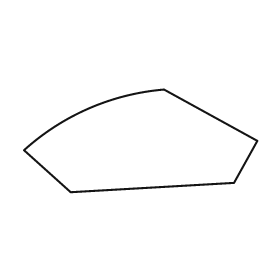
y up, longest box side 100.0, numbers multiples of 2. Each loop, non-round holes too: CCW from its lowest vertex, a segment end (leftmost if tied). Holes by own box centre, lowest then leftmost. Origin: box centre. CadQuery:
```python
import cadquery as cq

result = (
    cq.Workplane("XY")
    .moveTo(-30.0, -22.0)
    .lineTo(40.0, -18.0)
    .lineTo(50.0, 0.0)
    .lineTo(10.0, 22.0)
    .threePointArc((-22.0, 14.0), (-50.0, -4.0))
    .close()
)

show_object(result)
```